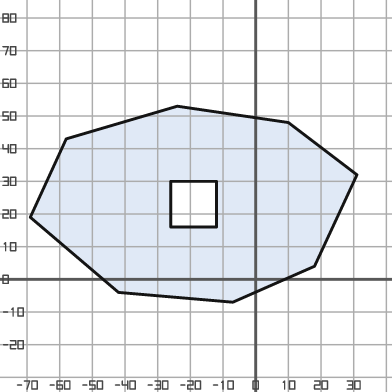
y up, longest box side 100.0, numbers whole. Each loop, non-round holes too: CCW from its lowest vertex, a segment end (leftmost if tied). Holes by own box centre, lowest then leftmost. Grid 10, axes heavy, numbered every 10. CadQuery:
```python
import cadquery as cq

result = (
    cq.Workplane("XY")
    .moveTo(-7.0, -7.0)
    .lineTo(18.0, 4.0)
    .lineTo(31.0, 32.0)
    .lineTo(10.0, 48.0)
    .lineTo(-24.0, 53.0)
    .lineTo(-58.0, 43.0)
    .lineTo(-69.0, 19.0)
    .lineTo(-42.0, -4.0)
    .close()
    .moveTo(-26.0, 16.0)
    .lineTo(-12.0, 16.0)
    .lineTo(-12.0, 30.0)
    .lineTo(-26.0, 30.0)
    .close()
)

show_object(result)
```